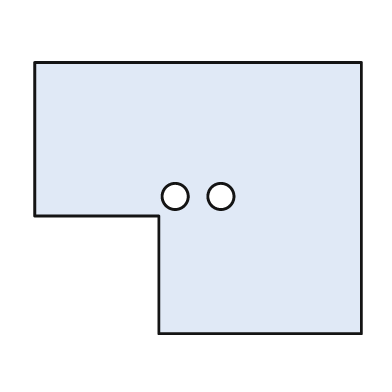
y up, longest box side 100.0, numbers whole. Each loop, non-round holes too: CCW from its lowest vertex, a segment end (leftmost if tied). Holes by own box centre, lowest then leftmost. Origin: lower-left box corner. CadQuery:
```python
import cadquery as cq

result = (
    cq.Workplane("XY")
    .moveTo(38.0, 0.0)
    .lineTo(100.0, 0.0)
    .lineTo(100.0, 83.0)
    .lineTo(0.0, 83.0)
    .lineTo(0.0, 36.0)
    .lineTo(38.0, 36.0)
    .close()
    .moveTo(43.0, 42.0)
    .circle(4.0)
    .moveTo(57.0, 42.0)
    .circle(4.0)
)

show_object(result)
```